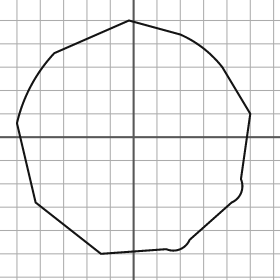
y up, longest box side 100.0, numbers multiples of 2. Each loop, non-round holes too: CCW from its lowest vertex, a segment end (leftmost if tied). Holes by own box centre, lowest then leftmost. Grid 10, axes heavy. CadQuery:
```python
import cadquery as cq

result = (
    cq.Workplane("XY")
    .moveTo(-14.0, -50.0)
    .lineTo(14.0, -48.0)
    .threePointArc((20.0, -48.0), (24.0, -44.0))
    .lineTo(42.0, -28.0)
    .threePointArc((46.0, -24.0), (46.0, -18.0))
    .lineTo(50.0, 10.0)
    .lineTo(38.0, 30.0)
    .threePointArc((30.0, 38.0), (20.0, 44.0))
    .lineTo(-2.0, 50.0)
    .lineTo(-34.0, 36.0)
    .threePointArc((-44.0, 22.0), (-50.0, 6.0))
    .lineTo(-42.0, -28.0)
    .close()
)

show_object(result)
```